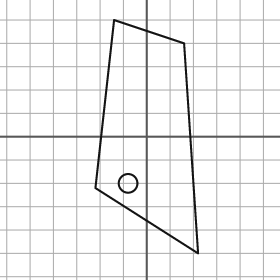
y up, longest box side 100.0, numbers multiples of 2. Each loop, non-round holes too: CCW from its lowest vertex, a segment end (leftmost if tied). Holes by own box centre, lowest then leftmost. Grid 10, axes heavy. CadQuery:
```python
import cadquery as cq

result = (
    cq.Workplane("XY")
    .moveTo(22.0, -50.0)
    .lineTo(16.0, 40.0)
    .lineTo(-14.0, 50.0)
    .lineTo(-22.0, -22.0)
    .close()
    .moveTo(-8.0, -20.0)
    .circle(4.0)
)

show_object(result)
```